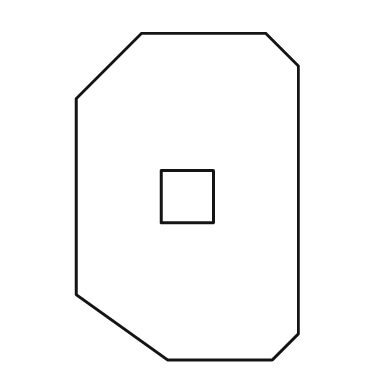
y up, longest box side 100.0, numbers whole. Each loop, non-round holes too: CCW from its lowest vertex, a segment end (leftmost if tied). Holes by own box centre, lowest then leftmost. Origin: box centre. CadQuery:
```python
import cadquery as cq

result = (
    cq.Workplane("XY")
    .moveTo(-6.0, -50.0)
    .lineTo(26.0, -50.0)
    .lineTo(34.0, -42.0)
    .lineTo(34.0, 40.0)
    .lineTo(24.0, 50.0)
    .lineTo(-14.0, 50.0)
    .lineTo(-34.0, 30.0)
    .lineTo(-34.0, -30.0)
    .close()
    .moveTo(-8.0, -8.0)
    .lineTo(8.0, -8.0)
    .lineTo(8.0, 8.0)
    .lineTo(-8.0, 8.0)
    .close()
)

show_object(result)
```